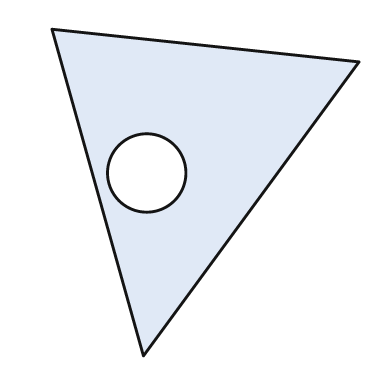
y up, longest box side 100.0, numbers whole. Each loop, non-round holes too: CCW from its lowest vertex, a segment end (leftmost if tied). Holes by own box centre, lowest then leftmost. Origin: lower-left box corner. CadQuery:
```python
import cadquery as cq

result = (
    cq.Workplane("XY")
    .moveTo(28.0, 0.0)
    .lineTo(94.0, 90.0)
    .lineTo(0.0, 100.0)
    .close()
    .moveTo(29.0, 56.0)
    .circle(12.0)
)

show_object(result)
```